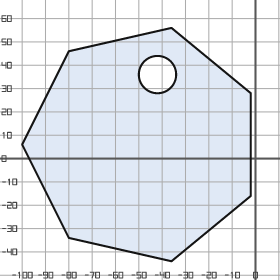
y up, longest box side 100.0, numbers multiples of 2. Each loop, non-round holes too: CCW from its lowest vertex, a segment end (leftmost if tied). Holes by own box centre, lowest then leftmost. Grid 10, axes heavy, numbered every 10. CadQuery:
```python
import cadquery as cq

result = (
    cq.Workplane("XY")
    .moveTo(-36.0, -44.0)
    .lineTo(-2.0, -16.0)
    .lineTo(-2.0, 28.0)
    .lineTo(-36.0, 56.0)
    .lineTo(-80.0, 46.0)
    .lineTo(-100.0, 6.0)
    .lineTo(-80.0, -34.0)
    .close()
    .moveTo(-42.0, 36.0)
    .circle(8.0)
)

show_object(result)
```